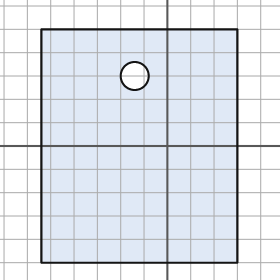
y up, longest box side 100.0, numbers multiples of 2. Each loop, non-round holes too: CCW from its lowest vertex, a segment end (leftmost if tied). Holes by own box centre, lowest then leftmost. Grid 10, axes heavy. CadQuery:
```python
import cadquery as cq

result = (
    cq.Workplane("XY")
    .moveTo(-54.0, -50.0)
    .lineTo(30.0, -50.0)
    .lineTo(30.0, 50.0)
    .lineTo(-54.0, 50.0)
    .close()
    .moveTo(-14.0, 30.0)
    .circle(6.0)
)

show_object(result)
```